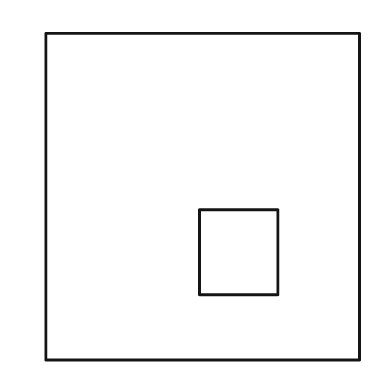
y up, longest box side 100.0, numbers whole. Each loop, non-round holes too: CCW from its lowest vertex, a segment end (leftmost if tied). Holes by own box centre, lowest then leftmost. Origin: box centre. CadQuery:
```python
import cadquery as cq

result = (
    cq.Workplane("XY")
    .moveTo(-48.0, -50.0)
    .lineTo(48.0, -50.0)
    .lineTo(48.0, 50.0)
    .lineTo(-48.0, 50.0)
    .close()
    .moveTo(-1.0, -30.0)
    .lineTo(23.0, -30.0)
    .lineTo(23.0, -4.0)
    .lineTo(-1.0, -4.0)
    .close()
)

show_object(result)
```